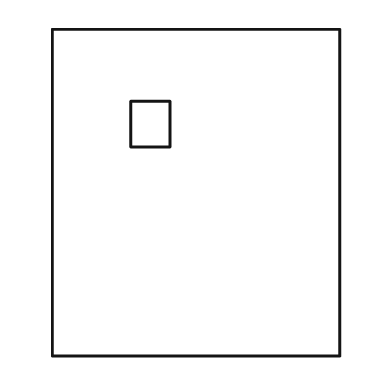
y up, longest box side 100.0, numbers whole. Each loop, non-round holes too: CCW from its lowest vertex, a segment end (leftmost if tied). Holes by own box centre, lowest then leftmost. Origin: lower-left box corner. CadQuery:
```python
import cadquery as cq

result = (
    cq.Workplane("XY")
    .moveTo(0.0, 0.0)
    .lineTo(88.0, 0.0)
    .lineTo(88.0, 100.0)
    .lineTo(0.0, 100.0)
    .close()
    .moveTo(24.0, 64.0)
    .lineTo(36.0, 64.0)
    .lineTo(36.0, 78.0)
    .lineTo(24.0, 78.0)
    .close()
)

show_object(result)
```